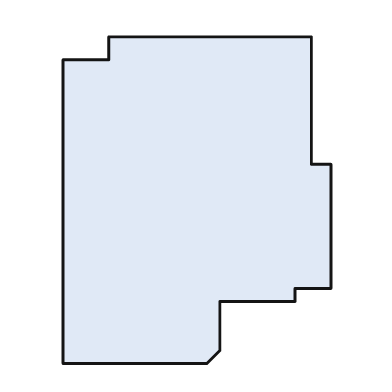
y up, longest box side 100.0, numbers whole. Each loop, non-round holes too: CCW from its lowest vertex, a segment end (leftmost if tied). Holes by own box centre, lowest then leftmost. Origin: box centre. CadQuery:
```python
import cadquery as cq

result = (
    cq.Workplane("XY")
    .moveTo(-41.0, -50.0)
    .lineTo(3.0, -50.0)
    .lineTo(7.0, -46.0)
    .lineTo(7.0, -31.0)
    .lineTo(30.0, -31.0)
    .lineTo(30.0, -27.0)
    .lineTo(41.0, -27.0)
    .lineTo(41.0, 11.0)
    .lineTo(35.0, 11.0)
    .lineTo(35.0, 50.0)
    .lineTo(-27.0, 50.0)
    .lineTo(-27.0, 43.0)
    .lineTo(-41.0, 43.0)
    .close()
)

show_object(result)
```